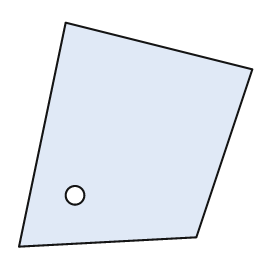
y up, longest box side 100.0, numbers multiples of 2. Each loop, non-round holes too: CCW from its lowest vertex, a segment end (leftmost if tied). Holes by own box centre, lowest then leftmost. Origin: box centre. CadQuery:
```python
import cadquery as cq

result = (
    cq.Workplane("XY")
    .moveTo(-50.0, -48.0)
    .lineTo(26.0, -44.0)
    .lineTo(50.0, 28.0)
    .lineTo(-30.0, 48.0)
    .close()
    .moveTo(-26.0, -26.0)
    .circle(4.0)
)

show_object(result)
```